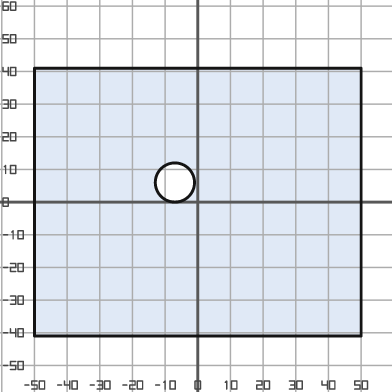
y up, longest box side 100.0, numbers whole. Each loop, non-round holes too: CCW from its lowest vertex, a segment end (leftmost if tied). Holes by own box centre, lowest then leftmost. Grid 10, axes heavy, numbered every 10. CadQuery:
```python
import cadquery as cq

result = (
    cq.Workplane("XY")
    .moveTo(-50.0, -41.0)
    .lineTo(50.0, -41.0)
    .lineTo(50.0, 41.0)
    .lineTo(-50.0, 41.0)
    .close()
    .moveTo(-7.0, 6.0)
    .circle(6.0)
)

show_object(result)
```